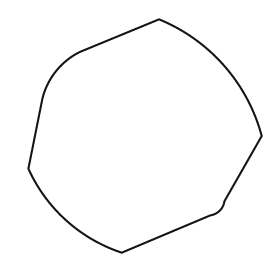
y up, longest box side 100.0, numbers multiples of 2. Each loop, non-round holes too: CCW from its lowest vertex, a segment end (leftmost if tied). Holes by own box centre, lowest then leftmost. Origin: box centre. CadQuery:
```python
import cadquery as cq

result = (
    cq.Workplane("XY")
    .moveTo(-10.0, -50.0)
    .lineTo(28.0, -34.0)
    .threePointArc((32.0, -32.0), (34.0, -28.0))
    .lineTo(50.0, 0.0)
    .threePointArc((34.0, 30.0), (6.0, 50.0))
    .lineTo(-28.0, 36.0)
    .threePointArc((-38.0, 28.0), (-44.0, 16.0))
    .lineTo(-50.0, -14.0)
    .threePointArc((-34.0, -36.0), (-10.0, -50.0))
    .close()
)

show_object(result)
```